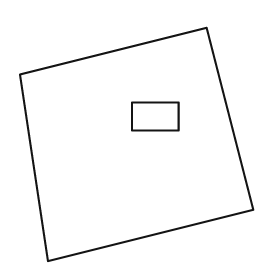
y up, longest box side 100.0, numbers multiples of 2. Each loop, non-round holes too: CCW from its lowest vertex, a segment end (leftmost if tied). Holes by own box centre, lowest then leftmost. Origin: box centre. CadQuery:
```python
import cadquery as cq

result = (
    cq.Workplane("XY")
    .moveTo(-38.0, -50.0)
    .lineTo(50.0, -28.0)
    .lineTo(30.0, 50.0)
    .lineTo(-50.0, 30.0)
    .close()
    .moveTo(-2.0, 6.0)
    .lineTo(18.0, 6.0)
    .lineTo(18.0, 18.0)
    .lineTo(-2.0, 18.0)
    .close()
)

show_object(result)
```